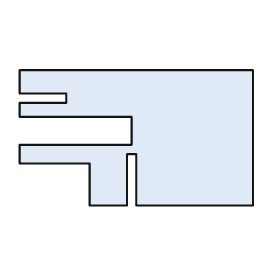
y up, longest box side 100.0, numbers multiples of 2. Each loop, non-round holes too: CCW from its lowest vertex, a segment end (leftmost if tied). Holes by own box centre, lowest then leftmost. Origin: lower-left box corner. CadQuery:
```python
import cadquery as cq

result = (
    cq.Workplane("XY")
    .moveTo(30.0, 0.0)
    .lineTo(46.0, 0.0)
    .lineTo(46.0, 22.0)
    .lineTo(50.0, 22.0)
    .lineTo(50.0, 0.0)
    .lineTo(100.0, 0.0)
    .lineTo(100.0, 58.0)
    .lineTo(0.0, 58.0)
    .lineTo(0.0, 48.0)
    .lineTo(20.0, 48.0)
    .lineTo(20.0, 44.0)
    .lineTo(0.0, 44.0)
    .lineTo(0.0, 38.0)
    .lineTo(48.0, 38.0)
    .lineTo(48.0, 26.0)
    .lineTo(0.0, 26.0)
    .lineTo(0.0, 18.0)
    .lineTo(30.0, 18.0)
    .close()
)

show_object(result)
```